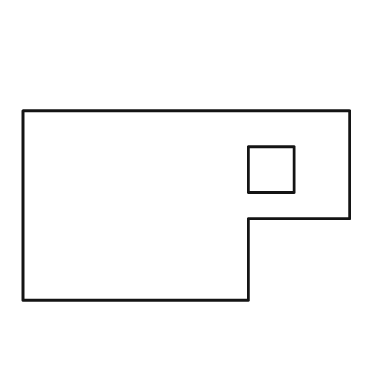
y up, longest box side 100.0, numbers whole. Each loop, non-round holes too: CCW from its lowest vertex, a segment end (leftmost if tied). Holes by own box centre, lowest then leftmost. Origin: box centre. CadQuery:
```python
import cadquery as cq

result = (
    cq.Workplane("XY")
    .moveTo(-50.0, -29.0)
    .lineTo(19.0, -29.0)
    .lineTo(19.0, -4.0)
    .lineTo(50.0, -4.0)
    .lineTo(50.0, 29.0)
    .lineTo(-50.0, 29.0)
    .close()
    .moveTo(19.0, 4.0)
    .lineTo(33.0, 4.0)
    .lineTo(33.0, 18.0)
    .lineTo(19.0, 18.0)
    .close()
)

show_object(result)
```